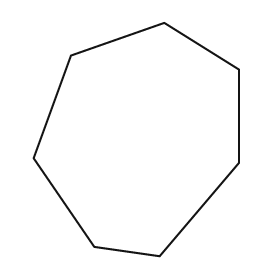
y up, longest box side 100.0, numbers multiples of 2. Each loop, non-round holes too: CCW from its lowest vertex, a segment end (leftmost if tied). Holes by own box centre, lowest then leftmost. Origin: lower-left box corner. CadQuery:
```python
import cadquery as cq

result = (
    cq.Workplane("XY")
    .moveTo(54.0, 0.0)
    .lineTo(88.0, 40.0)
    .lineTo(88.0, 80.0)
    .lineTo(56.0, 100.0)
    .lineTo(16.0, 86.0)
    .lineTo(0.0, 42.0)
    .lineTo(26.0, 4.0)
    .close()
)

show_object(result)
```